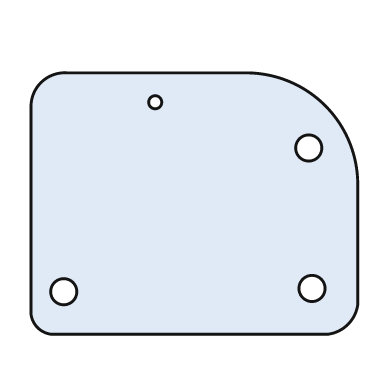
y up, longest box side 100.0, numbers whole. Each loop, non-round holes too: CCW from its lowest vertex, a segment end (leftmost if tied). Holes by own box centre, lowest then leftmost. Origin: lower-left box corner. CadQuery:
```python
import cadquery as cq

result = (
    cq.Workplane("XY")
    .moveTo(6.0, 0.0)
    .lineTo(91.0, 0.0)
    .threePointArc((97.0, 3.0), (100.0, 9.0))
    .lineTo(100.0, 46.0)
    .threePointArc((90.0, 70.0), (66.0, 80.0))
    .lineTo(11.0, 80.0)
    .threePointArc((3.0, 77.0), (0.0, 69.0))
    .lineTo(0.0, 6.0)
    .threePointArc((2.0, 2.0), (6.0, 0.0))
    .close()
    .moveTo(10.0, 13.0)
    .circle(4.0)
    .moveTo(86.0, 14.0)
    .circle(4.0)
    .moveTo(85.0, 57.0)
    .circle(4.0)
    .moveTo(38.0, 71.0)
    .circle(2.0)
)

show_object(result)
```